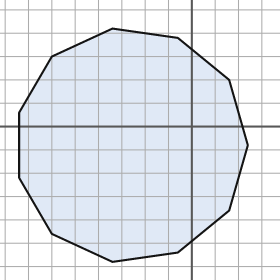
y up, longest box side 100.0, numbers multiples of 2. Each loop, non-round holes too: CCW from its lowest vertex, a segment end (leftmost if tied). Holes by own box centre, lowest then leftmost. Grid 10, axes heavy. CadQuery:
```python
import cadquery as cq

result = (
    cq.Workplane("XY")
    .moveTo(-34.0, -58.0)
    .lineTo(-6.0, -54.0)
    .lineTo(16.0, -36.0)
    .lineTo(24.0, -8.0)
    .lineTo(16.0, 20.0)
    .lineTo(-6.0, 38.0)
    .lineTo(-34.0, 42.0)
    .lineTo(-60.0, 30.0)
    .lineTo(-74.0, 6.0)
    .lineTo(-74.0, -22.0)
    .lineTo(-60.0, -46.0)
    .close()
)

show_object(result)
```